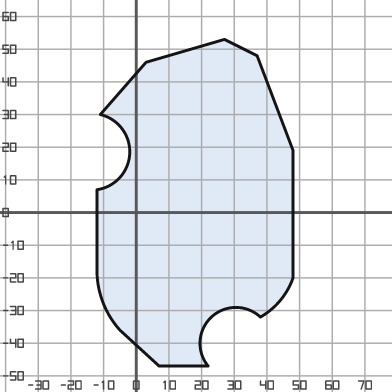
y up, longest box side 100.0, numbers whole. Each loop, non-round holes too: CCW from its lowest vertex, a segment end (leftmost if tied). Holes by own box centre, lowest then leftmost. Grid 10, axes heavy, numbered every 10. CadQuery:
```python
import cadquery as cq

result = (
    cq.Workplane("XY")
    .moveTo(7.0, -47.0)
    .lineTo(22.0, -47.0)
    .threePointArc((23.0, -32.0), (38.0, -32.0))
    .threePointArc((44.0, -27.0), (48.0, -20.0))
    .lineTo(48.0, 19.0)
    .lineTo(37.0, 48.0)
    .lineTo(27.0, 53.0)
    .lineTo(3.0, 46.0)
    .lineTo(-11.0, 30.0)
    .threePointArc((-2.0, 18.0), (-12.0, 7.0))
    .lineTo(-12.0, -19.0)
    .threePointArc((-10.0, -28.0), (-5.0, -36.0))
    .close()
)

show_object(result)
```